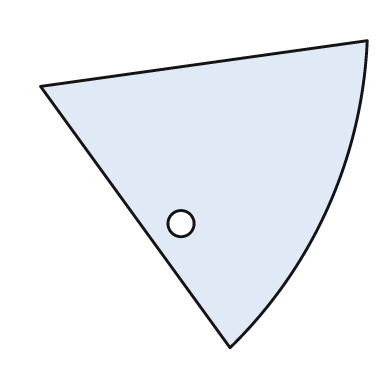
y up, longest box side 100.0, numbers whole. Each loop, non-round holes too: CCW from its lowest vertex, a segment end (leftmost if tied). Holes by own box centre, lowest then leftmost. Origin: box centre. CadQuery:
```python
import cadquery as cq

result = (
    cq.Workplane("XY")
    .moveTo(8.0, -47.0)
    .threePointArc((38.0, -4.0), (50.0, 47.0))
    .lineTo(-50.0, 33.0)
    .close()
    .moveTo(-7.0, -9.0)
    .circle(4.0)
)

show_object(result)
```